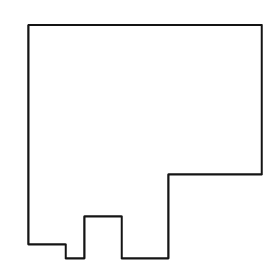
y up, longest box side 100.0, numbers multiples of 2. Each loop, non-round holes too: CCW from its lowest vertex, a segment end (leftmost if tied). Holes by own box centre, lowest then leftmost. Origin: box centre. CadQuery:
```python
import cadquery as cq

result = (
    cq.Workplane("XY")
    .moveTo(-34.0, -50.0)
    .lineTo(-26.0, -50.0)
    .lineTo(-26.0, -32.0)
    .lineTo(-10.0, -32.0)
    .lineTo(-10.0, -50.0)
    .lineTo(10.0, -50.0)
    .lineTo(10.0, -14.0)
    .lineTo(50.0, -14.0)
    .lineTo(50.0, 50.0)
    .lineTo(-50.0, 50.0)
    .lineTo(-50.0, -44.0)
    .lineTo(-34.0, -44.0)
    .close()
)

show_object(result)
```